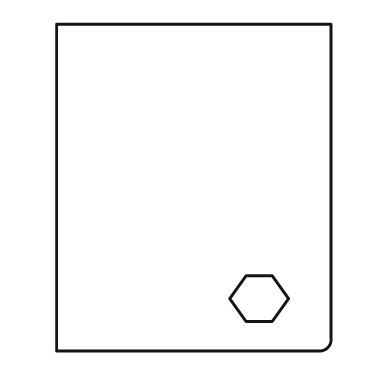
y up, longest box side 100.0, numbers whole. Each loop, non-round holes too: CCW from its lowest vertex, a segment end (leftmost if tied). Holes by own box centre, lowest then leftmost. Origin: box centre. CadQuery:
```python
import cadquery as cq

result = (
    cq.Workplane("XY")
    .moveTo(-42.0, -50.0)
    .lineTo(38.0, -50.0)
    .threePointArc((41.0, -49.0), (42.0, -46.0))
    .lineTo(42.0, 50.0)
    .lineTo(-42.0, 50.0)
    .close()
    .moveTo(16.0, -41.0)
    .lineTo(24.0, -41.0)
    .lineTo(29.0, -34.0)
    .lineTo(24.0, -27.0)
    .lineTo(16.0, -27.0)
    .lineTo(11.0, -34.0)
    .close()
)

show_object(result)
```